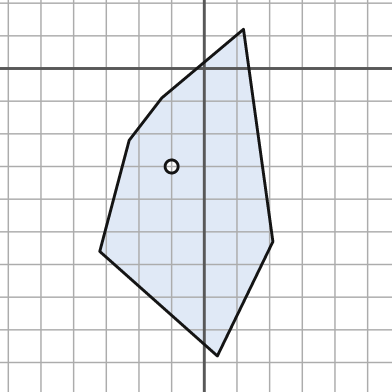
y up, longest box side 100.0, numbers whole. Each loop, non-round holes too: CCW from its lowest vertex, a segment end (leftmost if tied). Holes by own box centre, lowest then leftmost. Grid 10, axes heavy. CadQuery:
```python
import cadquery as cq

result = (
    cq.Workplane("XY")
    .moveTo(4.0, -88.0)
    .lineTo(21.0, -53.0)
    .lineTo(12.0, 12.0)
    .lineTo(-13.0, -9.0)
    .lineTo(-23.0, -22.0)
    .lineTo(-32.0, -56.0)
    .close()
    .moveTo(-10.0, -30.0)
    .circle(2.0)
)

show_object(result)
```